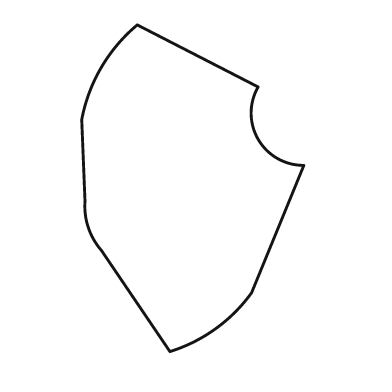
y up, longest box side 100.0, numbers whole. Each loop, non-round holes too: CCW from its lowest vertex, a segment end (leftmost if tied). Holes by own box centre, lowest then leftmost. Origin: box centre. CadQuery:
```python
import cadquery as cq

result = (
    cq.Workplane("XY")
    .moveTo(-7.0, -50.0)
    .threePointArc((7.0, -43.0), (18.0, -32.0))
    .lineTo(34.0, 7.0)
    .threePointArc((20.0, 15.0), (20.0, 31.0))
    .lineTo(-17.0, 50.0)
    .threePointArc((-28.0, 37.0), (-34.0, 21.0))
    .lineTo(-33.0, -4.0)
    .threePointArc((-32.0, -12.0), (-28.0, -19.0))
    .close()
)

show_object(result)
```